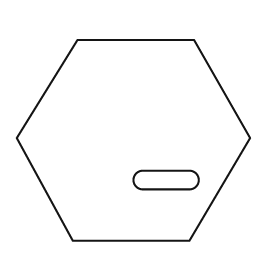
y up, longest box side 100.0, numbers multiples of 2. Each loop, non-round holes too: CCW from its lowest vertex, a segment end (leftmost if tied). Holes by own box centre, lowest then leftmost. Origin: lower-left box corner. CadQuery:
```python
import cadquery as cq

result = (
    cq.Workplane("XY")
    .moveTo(24.0, 0.0)
    .lineTo(74.0, 0.0)
    .lineTo(100.0, 44.0)
    .lineTo(76.0, 86.0)
    .lineTo(26.0, 86.0)
    .lineTo(0.0, 44.0)
    .close()
    .moveTo(54.0, 22.0)
    .lineTo(74.0, 22.0)
    .threePointArc((78.0, 26.0), (74.0, 30.0))
    .lineTo(54.0, 30.0)
    .threePointArc((50.0, 26.0), (54.0, 22.0))
    .close()
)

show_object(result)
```